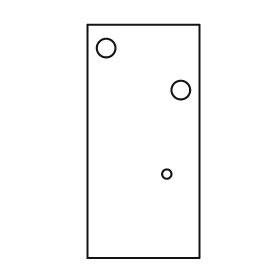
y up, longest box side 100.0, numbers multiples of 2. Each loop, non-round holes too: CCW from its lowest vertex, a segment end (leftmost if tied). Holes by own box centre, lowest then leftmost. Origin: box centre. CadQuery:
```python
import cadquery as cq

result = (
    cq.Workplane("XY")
    .moveTo(-24.0, -50.0)
    .lineTo(24.0, -50.0)
    .lineTo(24.0, 50.0)
    .lineTo(-24.0, 50.0)
    .close()
    .moveTo(10.0, -14.0)
    .circle(2.0)
    .moveTo(16.0, 22.0)
    .circle(4.0)
    .moveTo(-16.0, 40.0)
    .circle(4.0)
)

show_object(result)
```